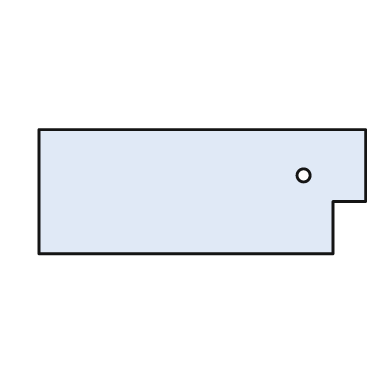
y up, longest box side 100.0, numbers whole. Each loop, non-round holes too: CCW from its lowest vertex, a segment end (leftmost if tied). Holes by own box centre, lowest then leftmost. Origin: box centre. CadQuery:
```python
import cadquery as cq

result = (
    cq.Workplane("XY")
    .moveTo(-50.0, -19.0)
    .lineTo(40.0, -19.0)
    .lineTo(40.0, -3.0)
    .lineTo(50.0, -3.0)
    .lineTo(50.0, 19.0)
    .lineTo(-50.0, 19.0)
    .close()
    .moveTo(31.0, 5.0)
    .circle(2.0)
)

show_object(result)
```